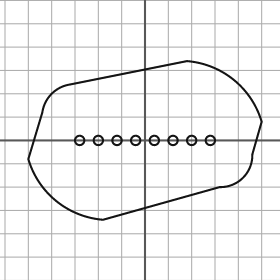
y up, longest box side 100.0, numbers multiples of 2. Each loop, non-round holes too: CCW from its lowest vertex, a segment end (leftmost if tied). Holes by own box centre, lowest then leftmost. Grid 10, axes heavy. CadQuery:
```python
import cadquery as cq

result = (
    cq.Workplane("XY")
    .moveTo(-18.0, -34.0)
    .lineTo(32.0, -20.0)
    .threePointArc((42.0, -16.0), (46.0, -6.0))
    .lineTo(50.0, 8.0)
    .threePointArc((38.0, 26.0), (18.0, 34.0))
    .lineTo(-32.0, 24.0)
    .threePointArc((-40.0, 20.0), (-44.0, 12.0))
    .lineTo(-50.0, -8.0)
    .threePointArc((-38.0, -26.0), (-18.0, -34.0))
    .close()
    .moveTo(-28.0, 0.0)
    .circle(2.0)
    .moveTo(-20.0, 0.0)
    .circle(2.0)
    .moveTo(-12.0, 0.0)
    .circle(2.0)
    .moveTo(-4.0, 0.0)
    .circle(2.0)
    .moveTo(4.0, 0.0)
    .circle(2.0)
    .moveTo(12.0, 0.0)
    .circle(2.0)
    .moveTo(20.0, 0.0)
    .circle(2.0)
    .moveTo(28.0, 0.0)
    .circle(2.0)
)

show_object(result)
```